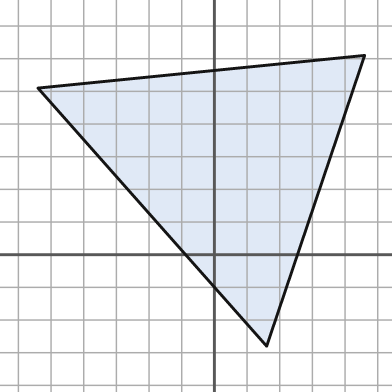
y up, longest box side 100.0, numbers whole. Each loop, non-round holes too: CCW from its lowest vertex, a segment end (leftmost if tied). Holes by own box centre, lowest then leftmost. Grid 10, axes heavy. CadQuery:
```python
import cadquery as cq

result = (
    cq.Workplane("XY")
    .moveTo(16.0, -28.0)
    .lineTo(46.0, 61.0)
    .lineTo(-54.0, 51.0)
    .close()
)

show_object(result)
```